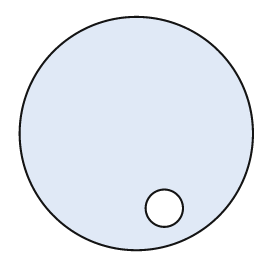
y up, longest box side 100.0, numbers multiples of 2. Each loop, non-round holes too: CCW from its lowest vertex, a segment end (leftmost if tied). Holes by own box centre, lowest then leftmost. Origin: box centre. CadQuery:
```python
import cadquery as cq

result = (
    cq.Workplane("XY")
    .moveTo(0.0, 0.0)
    .circle(50.0)
    .moveTo(12.0, -32.0)
    .circle(8.0)
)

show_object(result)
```